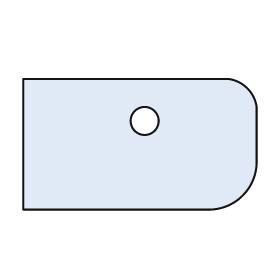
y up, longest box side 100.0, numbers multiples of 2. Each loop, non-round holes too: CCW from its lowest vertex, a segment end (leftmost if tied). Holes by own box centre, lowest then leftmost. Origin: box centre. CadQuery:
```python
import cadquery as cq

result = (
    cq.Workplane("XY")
    .moveTo(-50.0, -28.0)
    .lineTo(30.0, -28.0)
    .threePointArc((44.0, -22.0), (50.0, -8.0))
    .lineTo(50.0, 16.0)
    .threePointArc((46.0, 24.0), (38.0, 28.0))
    .lineTo(-50.0, 28.0)
    .close()
    .moveTo(2.0, 10.0)
    .circle(6.0)
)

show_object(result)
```